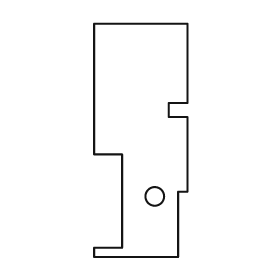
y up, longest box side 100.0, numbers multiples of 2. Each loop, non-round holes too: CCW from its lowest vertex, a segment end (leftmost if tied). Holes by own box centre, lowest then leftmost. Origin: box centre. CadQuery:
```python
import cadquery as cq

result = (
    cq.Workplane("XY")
    .moveTo(-20.0, -50.0)
    .lineTo(16.0, -50.0)
    .lineTo(16.0, -22.0)
    .lineTo(20.0, -22.0)
    .lineTo(20.0, 10.0)
    .lineTo(12.0, 10.0)
    .lineTo(12.0, 16.0)
    .lineTo(20.0, 16.0)
    .lineTo(20.0, 50.0)
    .lineTo(-20.0, 50.0)
    .lineTo(-20.0, -6.0)
    .lineTo(-8.0, -6.0)
    .lineTo(-8.0, -46.0)
    .lineTo(-20.0, -46.0)
    .close()
    .moveTo(6.0, -24.0)
    .circle(4.0)
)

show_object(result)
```